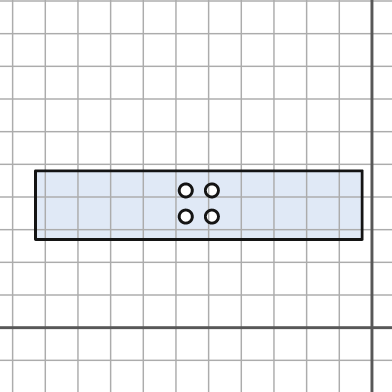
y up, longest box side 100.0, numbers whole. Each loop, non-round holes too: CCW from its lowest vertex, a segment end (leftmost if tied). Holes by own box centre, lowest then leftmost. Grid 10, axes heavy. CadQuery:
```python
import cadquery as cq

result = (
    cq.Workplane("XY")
    .moveTo(-103.0, 27.0)
    .lineTo(-3.0, 27.0)
    .lineTo(-3.0, 48.0)
    .lineTo(-103.0, 48.0)
    .close()
    .moveTo(-57.0, 34.0)
    .circle(2.0)
    .moveTo(-49.0, 34.0)
    .circle(2.0)
    .moveTo(-57.0, 42.0)
    .circle(2.0)
    .moveTo(-49.0, 42.0)
    .circle(2.0)
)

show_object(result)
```